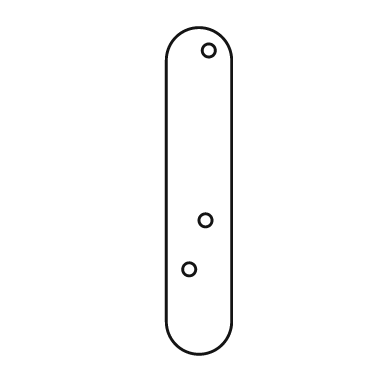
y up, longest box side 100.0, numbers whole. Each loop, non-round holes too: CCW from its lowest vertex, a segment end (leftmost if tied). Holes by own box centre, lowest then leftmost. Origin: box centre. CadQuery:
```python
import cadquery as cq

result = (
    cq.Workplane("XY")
    .moveTo(-10.0, -40.0)
    .threePointArc((0.0, -50.0), (10.0, -40.0))
    .lineTo(10.0, 40.0)
    .threePointArc((0.0, 50.0), (-10.0, 40.0))
    .close()
    .moveTo(-3.0, -24.0)
    .circle(2.0)
    .moveTo(2.0, -9.0)
    .circle(2.0)
    .moveTo(3.0, 43.0)
    .circle(2.0)
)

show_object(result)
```